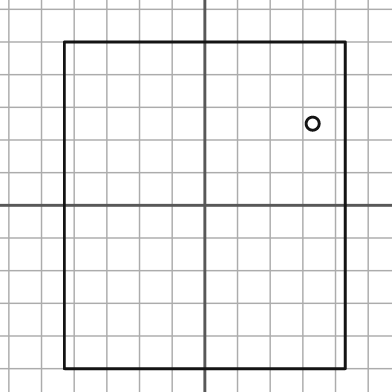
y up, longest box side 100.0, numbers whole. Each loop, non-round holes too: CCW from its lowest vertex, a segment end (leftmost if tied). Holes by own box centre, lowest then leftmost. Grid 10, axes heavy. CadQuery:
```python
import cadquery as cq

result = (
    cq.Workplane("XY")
    .moveTo(-43.0, -50.0)
    .lineTo(43.0, -50.0)
    .lineTo(43.0, 50.0)
    .lineTo(-43.0, 50.0)
    .close()
    .moveTo(33.0, 25.0)
    .circle(2.0)
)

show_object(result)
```